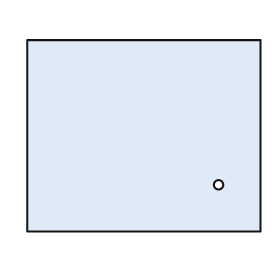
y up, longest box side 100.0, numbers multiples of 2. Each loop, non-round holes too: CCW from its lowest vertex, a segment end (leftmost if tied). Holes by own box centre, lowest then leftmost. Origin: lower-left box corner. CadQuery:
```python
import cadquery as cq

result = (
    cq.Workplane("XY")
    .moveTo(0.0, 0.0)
    .lineTo(100.0, 0.0)
    .lineTo(100.0, 82.0)
    .lineTo(0.0, 82.0)
    .close()
    .moveTo(82.0, 20.0)
    .circle(2.0)
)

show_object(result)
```